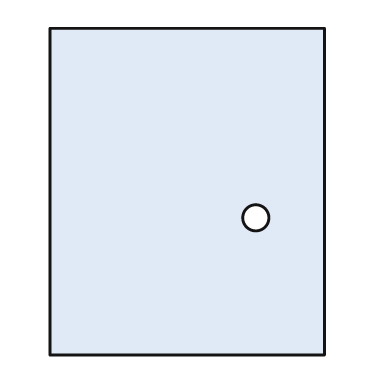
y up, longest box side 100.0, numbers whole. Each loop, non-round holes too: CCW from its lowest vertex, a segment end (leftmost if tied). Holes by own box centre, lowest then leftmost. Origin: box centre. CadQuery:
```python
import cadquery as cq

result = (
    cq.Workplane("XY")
    .moveTo(-42.0, -50.0)
    .lineTo(42.0, -50.0)
    .lineTo(42.0, 50.0)
    .lineTo(-42.0, 50.0)
    .close()
    .moveTo(21.0, -8.0)
    .circle(4.0)
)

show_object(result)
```